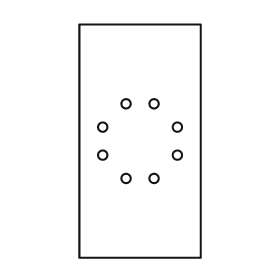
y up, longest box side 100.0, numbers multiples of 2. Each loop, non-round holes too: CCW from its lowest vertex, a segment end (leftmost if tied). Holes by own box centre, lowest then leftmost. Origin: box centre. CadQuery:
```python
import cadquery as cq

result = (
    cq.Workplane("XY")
    .moveTo(-26.0, -50.0)
    .lineTo(26.0, -50.0)
    .lineTo(26.0, 50.0)
    .lineTo(-26.0, 50.0)
    .close()
    .moveTo(-6.0, -16.0)
    .circle(2.0)
    .moveTo(6.0, -16.0)
    .circle(2.0)
    .moveTo(-16.0, -6.0)
    .circle(2.0)
    .moveTo(16.0, -6.0)
    .circle(2.0)
    .moveTo(-16.0, 6.0)
    .circle(2.0)
    .moveTo(16.0, 6.0)
    .circle(2.0)
    .moveTo(-6.0, 16.0)
    .circle(2.0)
    .moveTo(6.0, 16.0)
    .circle(2.0)
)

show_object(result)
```